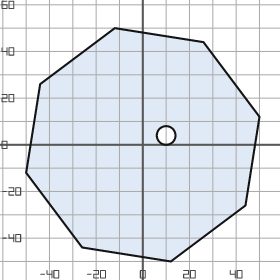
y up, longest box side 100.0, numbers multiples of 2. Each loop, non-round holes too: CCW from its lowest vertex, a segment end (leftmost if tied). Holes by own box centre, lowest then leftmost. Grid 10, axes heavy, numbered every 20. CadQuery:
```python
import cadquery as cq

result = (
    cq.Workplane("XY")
    .moveTo(12.0, -50.0)
    .lineTo(44.0, -26.0)
    .lineTo(50.0, 12.0)
    .lineTo(26.0, 44.0)
    .lineTo(-12.0, 50.0)
    .lineTo(-44.0, 26.0)
    .lineTo(-50.0, -12.0)
    .lineTo(-26.0, -44.0)
    .close()
    .moveTo(10.0, 4.0)
    .circle(4.0)
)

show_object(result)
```